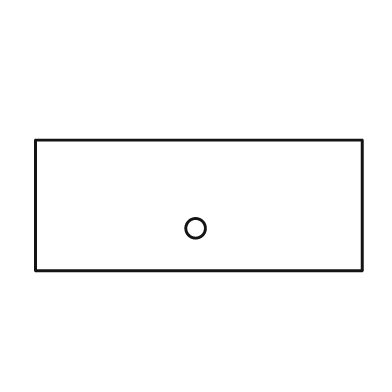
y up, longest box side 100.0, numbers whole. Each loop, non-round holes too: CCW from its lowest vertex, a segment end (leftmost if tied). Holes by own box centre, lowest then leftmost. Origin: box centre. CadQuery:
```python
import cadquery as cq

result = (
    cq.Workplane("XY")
    .moveTo(-50.0, -20.0)
    .lineTo(50.0, -20.0)
    .lineTo(50.0, 20.0)
    .lineTo(-50.0, 20.0)
    .close()
    .moveTo(-1.0, -7.0)
    .circle(3.0)
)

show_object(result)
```